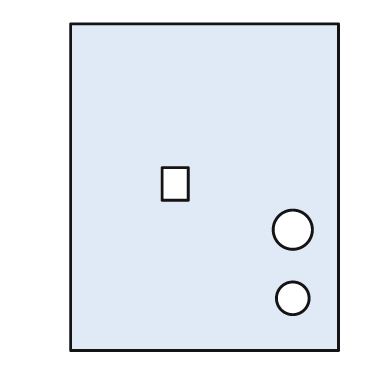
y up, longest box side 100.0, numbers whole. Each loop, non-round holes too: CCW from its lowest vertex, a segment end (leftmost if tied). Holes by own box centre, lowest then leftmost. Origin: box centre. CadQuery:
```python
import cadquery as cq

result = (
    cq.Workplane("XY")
    .moveTo(-41.0, -50.0)
    .lineTo(41.0, -50.0)
    .lineTo(41.0, 50.0)
    .lineTo(-41.0, 50.0)
    .close()
    .moveTo(27.0, -34.0)
    .circle(5.0)
    .moveTo(27.0, -13.0)
    .circle(6.0)
    .moveTo(-13.0, -4.0)
    .lineTo(-5.0, -4.0)
    .lineTo(-5.0, 6.0)
    .lineTo(-13.0, 6.0)
    .close()
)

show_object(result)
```